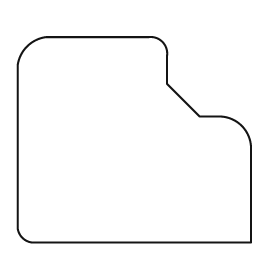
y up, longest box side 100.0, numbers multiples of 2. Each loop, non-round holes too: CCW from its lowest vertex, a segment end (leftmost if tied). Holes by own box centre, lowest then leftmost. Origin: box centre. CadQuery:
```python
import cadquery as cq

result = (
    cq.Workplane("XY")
    .moveTo(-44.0, -44.0)
    .lineTo(50.0, -44.0)
    .lineTo(50.0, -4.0)
    .threePointArc((46.0, 6.0), (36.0, 10.0))
    .lineTo(28.0, 10.0)
    .lineTo(14.0, 24.0)
    .lineTo(14.0, 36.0)
    .threePointArc((12.0, 42.0), (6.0, 44.0))
    .lineTo(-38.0, 44.0)
    .threePointArc((-46.0, 40.0), (-50.0, 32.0))
    .lineTo(-50.0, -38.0)
    .threePointArc((-48.0, -42.0), (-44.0, -44.0))
    .close()
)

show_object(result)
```